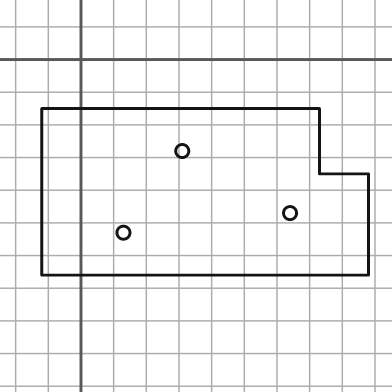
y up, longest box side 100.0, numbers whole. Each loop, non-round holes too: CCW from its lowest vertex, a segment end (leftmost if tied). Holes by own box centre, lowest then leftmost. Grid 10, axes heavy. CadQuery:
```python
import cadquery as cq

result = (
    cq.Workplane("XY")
    .moveTo(-12.0, -66.0)
    .lineTo(88.0, -66.0)
    .lineTo(88.0, -35.0)
    .lineTo(73.0, -35.0)
    .lineTo(73.0, -15.0)
    .lineTo(-12.0, -15.0)
    .close()
    .moveTo(13.0, -53.0)
    .circle(2.0)
    .moveTo(64.0, -47.0)
    .circle(2.0)
    .moveTo(31.0, -28.0)
    .circle(2.0)
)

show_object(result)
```